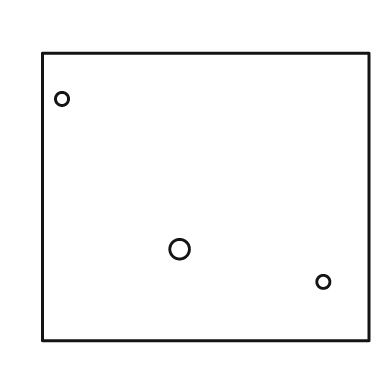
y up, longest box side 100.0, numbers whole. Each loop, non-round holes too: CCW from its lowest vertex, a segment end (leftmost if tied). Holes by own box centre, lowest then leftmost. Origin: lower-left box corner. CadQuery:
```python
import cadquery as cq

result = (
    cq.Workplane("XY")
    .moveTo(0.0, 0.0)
    .lineTo(100.0, 0.0)
    .lineTo(100.0, 88.0)
    .lineTo(0.0, 88.0)
    .close()
    .moveTo(86.0, 18.0)
    .circle(2.0)
    .moveTo(42.0, 28.0)
    .circle(3.0)
    .moveTo(6.0, 74.0)
    .circle(2.0)
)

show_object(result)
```